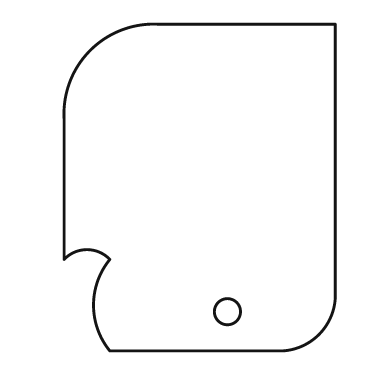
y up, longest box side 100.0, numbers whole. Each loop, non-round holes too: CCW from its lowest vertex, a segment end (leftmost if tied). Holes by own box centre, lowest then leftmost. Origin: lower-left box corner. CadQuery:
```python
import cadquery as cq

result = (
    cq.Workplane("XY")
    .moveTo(14.0, 0.0)
    .lineTo(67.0, 0.0)
    .threePointArc((78.0, 5.0), (83.0, 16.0))
    .lineTo(83.0, 100.0)
    .lineTo(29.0, 100.0)
    .threePointArc((8.0, 92.0), (0.0, 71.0))
    .lineTo(0.0, 28.0)
    .threePointArc((7.0, 31.0), (14.0, 28.0))
    .threePointArc((9.0, 14.0), (14.0, 0.0))
    .close()
    .moveTo(50.0, 12.0)
    .circle(4.0)
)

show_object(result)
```